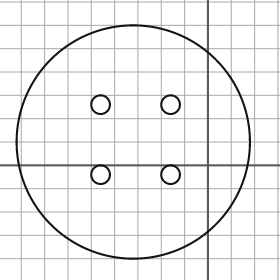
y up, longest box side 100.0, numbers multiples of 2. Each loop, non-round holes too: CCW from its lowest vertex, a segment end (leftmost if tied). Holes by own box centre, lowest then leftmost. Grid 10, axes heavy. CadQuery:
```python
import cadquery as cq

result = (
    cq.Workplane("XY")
    .moveTo(-32.0, 10.0)
    .circle(50.0)
    .moveTo(-46.0, -4.0)
    .circle(4.0)
    .moveTo(-16.0, -4.0)
    .circle(4.0)
    .moveTo(-46.0, 26.0)
    .circle(4.0)
    .moveTo(-16.0, 26.0)
    .circle(4.0)
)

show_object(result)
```